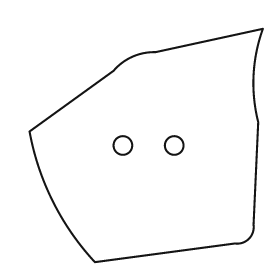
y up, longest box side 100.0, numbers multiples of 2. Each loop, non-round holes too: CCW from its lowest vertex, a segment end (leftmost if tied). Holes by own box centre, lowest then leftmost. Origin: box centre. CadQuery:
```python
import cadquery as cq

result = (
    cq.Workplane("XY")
    .moveTo(-22.0, -50.0)
    .lineTo(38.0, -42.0)
    .threePointArc((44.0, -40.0), (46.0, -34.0))
    .lineTo(48.0, 10.0)
    .threePointArc((46.0, 30.0), (50.0, 50.0))
    .lineTo(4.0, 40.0)
    .threePointArc((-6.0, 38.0), (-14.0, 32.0))
    .lineTo(-50.0, 6.0)
    .threePointArc((-40.0, -24.0), (-22.0, -50.0))
    .close()
    .moveTo(-10.0, 0.0)
    .circle(4.0)
    .moveTo(12.0, 0.0)
    .circle(4.0)
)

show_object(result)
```